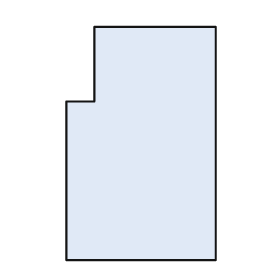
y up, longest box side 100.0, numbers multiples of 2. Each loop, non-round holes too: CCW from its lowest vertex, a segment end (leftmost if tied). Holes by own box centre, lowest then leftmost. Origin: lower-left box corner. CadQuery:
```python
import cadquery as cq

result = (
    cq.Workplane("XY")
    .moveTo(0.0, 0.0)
    .lineTo(64.0, 0.0)
    .lineTo(64.0, 100.0)
    .lineTo(12.0, 100.0)
    .lineTo(12.0, 68.0)
    .lineTo(0.0, 68.0)
    .close()
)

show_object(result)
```